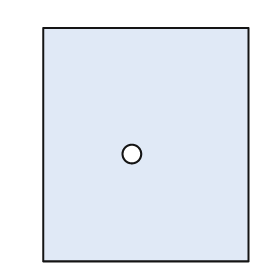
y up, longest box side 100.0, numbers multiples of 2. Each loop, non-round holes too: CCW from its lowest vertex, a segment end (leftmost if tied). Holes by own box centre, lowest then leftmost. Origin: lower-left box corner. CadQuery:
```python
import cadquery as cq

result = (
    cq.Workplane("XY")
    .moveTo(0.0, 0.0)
    .lineTo(88.0, 0.0)
    .lineTo(88.0, 100.0)
    .lineTo(0.0, 100.0)
    .close()
    .moveTo(38.0, 46.0)
    .circle(4.0)
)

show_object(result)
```